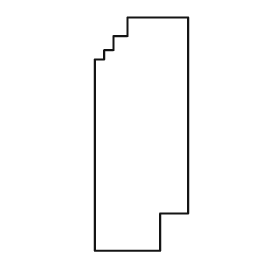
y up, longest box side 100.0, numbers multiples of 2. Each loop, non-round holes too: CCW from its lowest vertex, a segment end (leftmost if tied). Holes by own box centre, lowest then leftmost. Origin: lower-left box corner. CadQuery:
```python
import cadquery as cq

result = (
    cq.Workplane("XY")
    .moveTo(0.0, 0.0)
    .lineTo(28.0, 0.0)
    .lineTo(28.0, 16.0)
    .lineTo(40.0, 16.0)
    .lineTo(40.0, 100.0)
    .lineTo(14.0, 100.0)
    .lineTo(14.0, 92.0)
    .lineTo(8.0, 92.0)
    .lineTo(8.0, 86.0)
    .lineTo(4.0, 86.0)
    .lineTo(4.0, 82.0)
    .lineTo(0.0, 82.0)
    .close()
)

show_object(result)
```